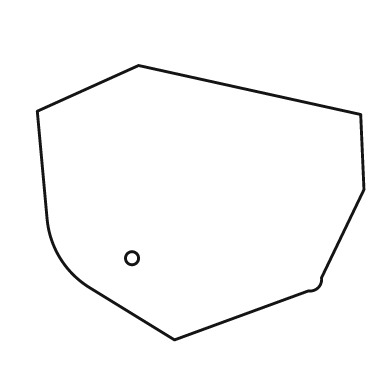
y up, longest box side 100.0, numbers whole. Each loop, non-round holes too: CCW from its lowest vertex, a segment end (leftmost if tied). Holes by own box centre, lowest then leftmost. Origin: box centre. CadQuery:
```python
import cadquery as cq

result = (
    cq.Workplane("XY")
    .moveTo(-8.0, -42.0)
    .lineTo(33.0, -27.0)
    .threePointArc((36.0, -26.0), (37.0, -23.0))
    .lineTo(50.0, 4.0)
    .lineTo(49.0, 27.0)
    .lineTo(-19.0, 42.0)
    .lineTo(-50.0, 28.0)
    .lineTo(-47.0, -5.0)
    .threePointArc((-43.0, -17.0), (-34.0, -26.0))
    .close()
    .moveTo(-21.0, -17.0)
    .circle(2.0)
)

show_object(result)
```